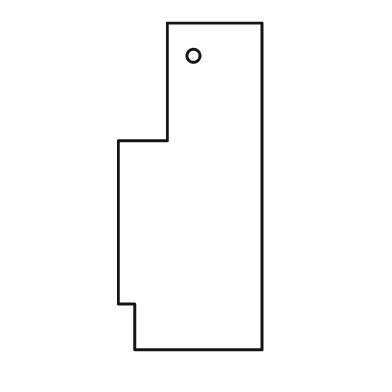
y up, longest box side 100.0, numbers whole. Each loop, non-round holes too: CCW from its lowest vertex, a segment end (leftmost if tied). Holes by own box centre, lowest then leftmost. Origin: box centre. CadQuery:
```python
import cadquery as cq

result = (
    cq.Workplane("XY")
    .moveTo(-17.0, -50.0)
    .lineTo(22.0, -50.0)
    .lineTo(22.0, 50.0)
    .lineTo(-7.0, 50.0)
    .lineTo(-7.0, 14.0)
    .lineTo(-22.0, 14.0)
    .lineTo(-22.0, -36.0)
    .lineTo(-17.0, -36.0)
    .close()
    .moveTo(1.0, 40.0)
    .circle(2.0)
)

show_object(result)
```